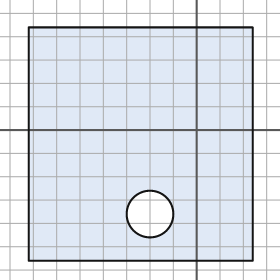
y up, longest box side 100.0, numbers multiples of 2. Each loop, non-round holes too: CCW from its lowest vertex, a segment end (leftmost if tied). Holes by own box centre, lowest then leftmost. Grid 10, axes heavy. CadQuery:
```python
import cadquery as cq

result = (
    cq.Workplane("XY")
    .moveTo(-72.0, -56.0)
    .lineTo(24.0, -56.0)
    .lineTo(24.0, 44.0)
    .lineTo(-72.0, 44.0)
    .close()
    .moveTo(-20.0, -36.0)
    .circle(10.0)
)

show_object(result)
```